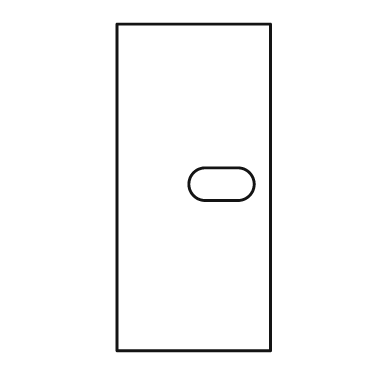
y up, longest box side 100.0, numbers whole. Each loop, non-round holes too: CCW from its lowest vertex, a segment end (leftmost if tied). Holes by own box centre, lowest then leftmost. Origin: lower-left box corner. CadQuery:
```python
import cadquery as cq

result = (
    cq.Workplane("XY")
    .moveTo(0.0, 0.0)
    .lineTo(47.0, 0.0)
    .lineTo(47.0, 100.0)
    .lineTo(0.0, 100.0)
    .close()
    .moveTo(27.0, 46.0)
    .lineTo(37.0, 46.0)
    .threePointArc((42.0, 51.0), (37.0, 56.0))
    .lineTo(27.0, 56.0)
    .threePointArc((22.0, 51.0), (27.0, 46.0))
    .close()
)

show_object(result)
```